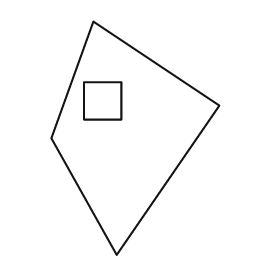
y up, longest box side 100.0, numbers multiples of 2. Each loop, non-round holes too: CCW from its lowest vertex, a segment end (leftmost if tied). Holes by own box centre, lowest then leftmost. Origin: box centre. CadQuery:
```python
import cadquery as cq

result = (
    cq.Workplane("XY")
    .moveTo(-8.0, -50.0)
    .lineTo(36.0, 14.0)
    .lineTo(-18.0, 50.0)
    .lineTo(-36.0, 0.0)
    .close()
    .moveTo(-22.0, 8.0)
    .lineTo(-6.0, 8.0)
    .lineTo(-6.0, 24.0)
    .lineTo(-22.0, 24.0)
    .close()
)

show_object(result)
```